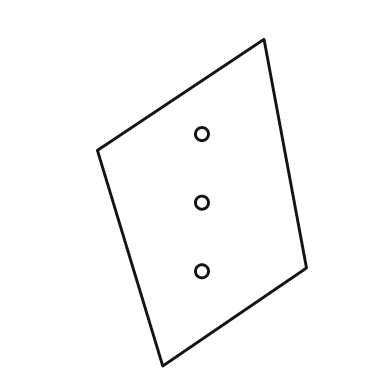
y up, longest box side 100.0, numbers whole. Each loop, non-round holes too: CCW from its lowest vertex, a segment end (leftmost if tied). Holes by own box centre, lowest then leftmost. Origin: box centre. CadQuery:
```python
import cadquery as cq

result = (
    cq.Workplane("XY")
    .moveTo(-12.0, -50.0)
    .lineTo(32.0, -20.0)
    .lineTo(19.0, 50.0)
    .lineTo(-32.0, 16.0)
    .close()
    .moveTo(0.0, -21.0)
    .circle(2.0)
    .moveTo(0.0, 0.0)
    .circle(2.0)
    .moveTo(0.0, 21.0)
    .circle(2.0)
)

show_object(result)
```